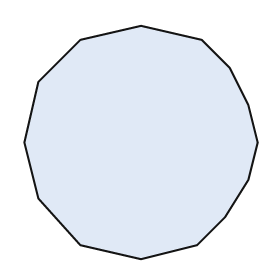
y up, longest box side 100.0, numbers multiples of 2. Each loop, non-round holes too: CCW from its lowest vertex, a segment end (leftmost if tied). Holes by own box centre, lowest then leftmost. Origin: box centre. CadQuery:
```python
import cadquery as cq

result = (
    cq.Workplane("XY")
    .moveTo(0.0, -50.0)
    .lineTo(24.0, -44.0)
    .lineTo(36.0, -32.0)
    .lineTo(46.0, -16.0)
    .lineTo(50.0, 0.0)
    .lineTo(46.0, 16.0)
    .lineTo(38.0, 32.0)
    .lineTo(26.0, 44.0)
    .lineTo(0.0, 50.0)
    .lineTo(-26.0, 44.0)
    .lineTo(-44.0, 26.0)
    .lineTo(-50.0, 0.0)
    .lineTo(-44.0, -24.0)
    .lineTo(-26.0, -44.0)
    .close()
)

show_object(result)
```